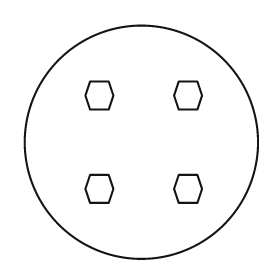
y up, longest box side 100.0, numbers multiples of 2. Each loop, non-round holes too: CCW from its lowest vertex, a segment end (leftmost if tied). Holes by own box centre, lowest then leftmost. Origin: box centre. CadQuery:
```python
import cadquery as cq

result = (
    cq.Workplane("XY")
    .moveTo(0.0, 0.0)
    .circle(50.0)
    .moveTo(-22.0, -26.0)
    .lineTo(-14.0, -26.0)
    .lineTo(-12.0, -20.0)
    .lineTo(-14.0, -14.0)
    .lineTo(-22.0, -14.0)
    .lineTo(-24.0, -20.0)
    .close()
    .moveTo(16.0, -26.0)
    .lineTo(24.0, -26.0)
    .lineTo(26.0, -20.0)
    .lineTo(24.0, -14.0)
    .lineTo(16.0, -14.0)
    .lineTo(14.0, -20.0)
    .close()
    .moveTo(-22.0, 14.0)
    .lineTo(-14.0, 14.0)
    .lineTo(-12.0, 20.0)
    .lineTo(-14.0, 26.0)
    .lineTo(-22.0, 26.0)
    .lineTo(-24.0, 20.0)
    .close()
    .moveTo(16.0, 14.0)
    .lineTo(24.0, 14.0)
    .lineTo(26.0, 20.0)
    .lineTo(24.0, 26.0)
    .lineTo(16.0, 26.0)
    .lineTo(14.0, 20.0)
    .close()
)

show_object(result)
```